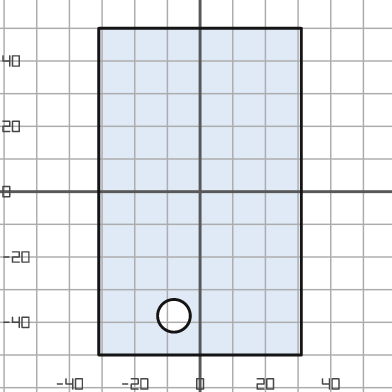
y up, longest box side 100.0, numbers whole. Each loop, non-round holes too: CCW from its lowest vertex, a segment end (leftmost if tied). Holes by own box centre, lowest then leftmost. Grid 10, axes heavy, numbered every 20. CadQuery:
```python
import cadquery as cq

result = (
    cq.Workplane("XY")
    .moveTo(-31.0, -50.0)
    .lineTo(31.0, -50.0)
    .lineTo(31.0, 50.0)
    .lineTo(-31.0, 50.0)
    .close()
    .moveTo(-8.0, -38.0)
    .circle(5.0)
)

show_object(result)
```